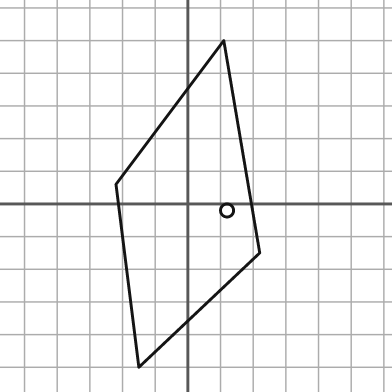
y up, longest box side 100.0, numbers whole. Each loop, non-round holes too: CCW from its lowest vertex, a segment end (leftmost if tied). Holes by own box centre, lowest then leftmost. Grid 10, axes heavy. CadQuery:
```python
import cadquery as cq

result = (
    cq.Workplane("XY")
    .moveTo(-15.0, -50.0)
    .lineTo(22.0, -15.0)
    .lineTo(11.0, 50.0)
    .lineTo(-22.0, 6.0)
    .close()
    .moveTo(12.0, -2.0)
    .circle(2.0)
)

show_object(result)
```